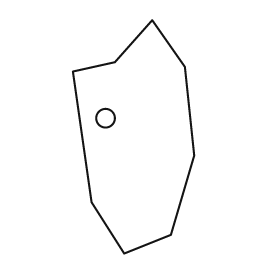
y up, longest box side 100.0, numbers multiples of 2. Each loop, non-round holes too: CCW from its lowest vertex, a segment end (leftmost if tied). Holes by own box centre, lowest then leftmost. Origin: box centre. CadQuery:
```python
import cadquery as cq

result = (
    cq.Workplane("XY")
    .moveTo(-4.0, -50.0)
    .lineTo(16.0, -42.0)
    .lineTo(26.0, -8.0)
    .lineTo(22.0, 30.0)
    .lineTo(8.0, 50.0)
    .lineTo(-8.0, 32.0)
    .lineTo(-26.0, 28.0)
    .lineTo(-18.0, -28.0)
    .close()
    .moveTo(-12.0, 8.0)
    .circle(4.0)
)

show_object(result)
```